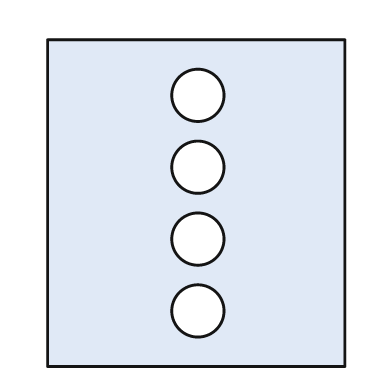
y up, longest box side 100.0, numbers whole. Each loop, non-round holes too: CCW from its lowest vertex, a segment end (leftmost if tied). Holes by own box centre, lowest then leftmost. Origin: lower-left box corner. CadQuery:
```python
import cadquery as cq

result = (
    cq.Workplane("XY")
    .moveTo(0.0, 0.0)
    .lineTo(91.0, 0.0)
    .lineTo(91.0, 100.0)
    .lineTo(0.0, 100.0)
    .close()
    .moveTo(46.0, 17.0)
    .circle(8.0)
    .moveTo(46.0, 39.0)
    .circle(8.0)
    .moveTo(46.0, 61.0)
    .circle(8.0)
    .moveTo(46.0, 83.0)
    .circle(8.0)
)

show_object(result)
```